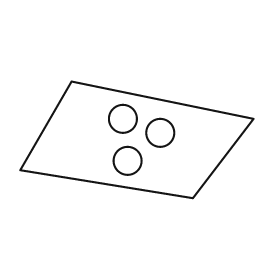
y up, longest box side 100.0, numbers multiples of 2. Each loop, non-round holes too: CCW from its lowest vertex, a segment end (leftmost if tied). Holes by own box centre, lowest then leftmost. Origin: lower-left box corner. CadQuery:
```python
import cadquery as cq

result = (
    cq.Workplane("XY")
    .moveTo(74.0, 0.0)
    .lineTo(100.0, 34.0)
    .lineTo(22.0, 50.0)
    .lineTo(0.0, 12.0)
    .close()
    .moveTo(46.0, 16.0)
    .circle(6.0)
    .moveTo(60.0, 28.0)
    .circle(6.0)
    .moveTo(44.0, 34.0)
    .circle(6.0)
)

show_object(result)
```